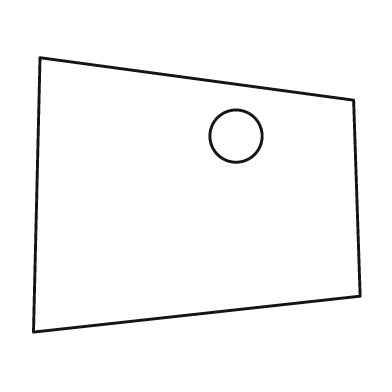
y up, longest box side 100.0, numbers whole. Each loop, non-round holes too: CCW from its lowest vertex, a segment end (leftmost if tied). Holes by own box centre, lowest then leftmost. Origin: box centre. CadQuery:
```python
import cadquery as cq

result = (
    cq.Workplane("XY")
    .moveTo(-50.0, -42.0)
    .lineTo(50.0, -31.0)
    .lineTo(48.0, 29.0)
    .lineTo(-48.0, 42.0)
    .close()
    .moveTo(12.0, 18.0)
    .circle(8.0)
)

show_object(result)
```